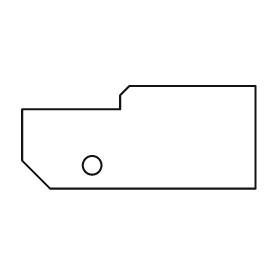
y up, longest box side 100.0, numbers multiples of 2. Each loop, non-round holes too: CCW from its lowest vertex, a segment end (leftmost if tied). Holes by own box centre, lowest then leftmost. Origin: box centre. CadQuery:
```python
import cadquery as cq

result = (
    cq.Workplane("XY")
    .moveTo(-38.0, -22.0)
    .lineTo(50.0, -22.0)
    .lineTo(50.0, 22.0)
    .lineTo(-4.0, 22.0)
    .lineTo(-8.0, 18.0)
    .lineTo(-8.0, 12.0)
    .lineTo(-50.0, 12.0)
    .lineTo(-50.0, -10.0)
    .close()
    .moveTo(-20.0, -12.0)
    .circle(4.0)
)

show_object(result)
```